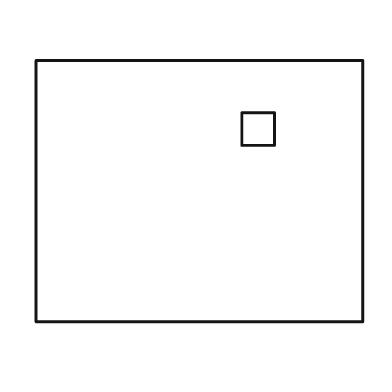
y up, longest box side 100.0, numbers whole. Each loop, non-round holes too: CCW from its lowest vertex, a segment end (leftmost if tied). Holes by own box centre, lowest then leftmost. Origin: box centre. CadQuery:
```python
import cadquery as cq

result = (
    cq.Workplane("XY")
    .moveTo(-50.0, -40.0)
    .lineTo(50.0, -40.0)
    .lineTo(50.0, 40.0)
    .lineTo(-50.0, 40.0)
    .close()
    .moveTo(13.0, 14.0)
    .lineTo(23.0, 14.0)
    .lineTo(23.0, 24.0)
    .lineTo(13.0, 24.0)
    .close()
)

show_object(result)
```